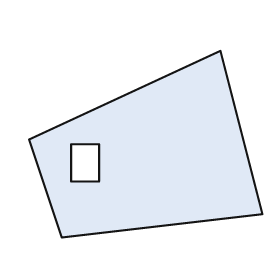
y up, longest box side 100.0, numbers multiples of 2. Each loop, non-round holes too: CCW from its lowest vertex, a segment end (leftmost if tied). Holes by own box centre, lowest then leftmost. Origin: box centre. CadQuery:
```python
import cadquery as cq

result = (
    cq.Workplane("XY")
    .moveTo(-36.0, -40.0)
    .lineTo(50.0, -30.0)
    .lineTo(32.0, 40.0)
    .lineTo(-50.0, 2.0)
    .close()
    .moveTo(-32.0, -16.0)
    .lineTo(-20.0, -16.0)
    .lineTo(-20.0, 0.0)
    .lineTo(-32.0, 0.0)
    .close()
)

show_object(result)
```